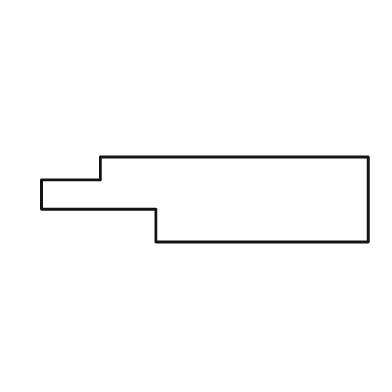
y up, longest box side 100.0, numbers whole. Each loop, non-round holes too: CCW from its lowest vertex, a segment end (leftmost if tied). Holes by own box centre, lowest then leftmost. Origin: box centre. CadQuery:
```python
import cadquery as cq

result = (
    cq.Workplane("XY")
    .moveTo(-15.0, -13.0)
    .lineTo(50.0, -13.0)
    .lineTo(50.0, 13.0)
    .lineTo(-32.0, 13.0)
    .lineTo(-32.0, 6.0)
    .lineTo(-50.0, 6.0)
    .lineTo(-50.0, -3.0)
    .lineTo(-15.0, -3.0)
    .close()
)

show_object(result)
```